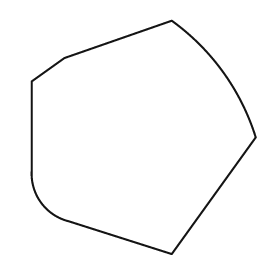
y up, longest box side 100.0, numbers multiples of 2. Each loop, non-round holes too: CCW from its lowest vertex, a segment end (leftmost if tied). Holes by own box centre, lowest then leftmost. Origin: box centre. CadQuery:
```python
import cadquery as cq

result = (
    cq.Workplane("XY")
    .moveTo(12.0, -50.0)
    .lineTo(48.0, 0.0)
    .threePointArc((34.0, 28.0), (12.0, 50.0))
    .lineTo(-34.0, 34.0)
    .lineTo(-48.0, 24.0)
    .lineTo(-48.0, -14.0)
    .threePointArc((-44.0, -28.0), (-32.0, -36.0))
    .close()
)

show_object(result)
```